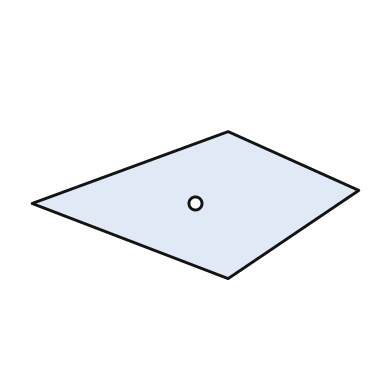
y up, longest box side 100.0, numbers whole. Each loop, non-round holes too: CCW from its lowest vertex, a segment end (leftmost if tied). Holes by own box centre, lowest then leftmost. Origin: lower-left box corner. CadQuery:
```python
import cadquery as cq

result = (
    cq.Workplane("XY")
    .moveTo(60.0, 0.0)
    .lineTo(100.0, 27.0)
    .lineTo(60.0, 45.0)
    .lineTo(0.0, 23.0)
    .close()
    .moveTo(50.0, 23.0)
    .circle(2.0)
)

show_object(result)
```